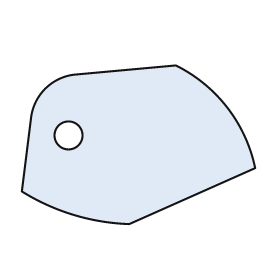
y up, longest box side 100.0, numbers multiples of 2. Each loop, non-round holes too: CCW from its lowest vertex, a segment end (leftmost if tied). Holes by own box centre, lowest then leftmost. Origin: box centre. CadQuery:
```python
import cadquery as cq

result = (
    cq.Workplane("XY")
    .moveTo(-4.0, -34.0)
    .lineTo(50.0, -10.0)
    .threePointArc((38.0, 16.0), (16.0, 34.0))
    .lineTo(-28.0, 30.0)
    .threePointArc((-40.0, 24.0), (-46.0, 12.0))
    .lineTo(-50.0, -20.0)
    .threePointArc((-28.0, -30.0), (-4.0, -34.0))
    .close()
    .moveTo(-30.0, 4.0)
    .circle(6.0)
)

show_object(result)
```